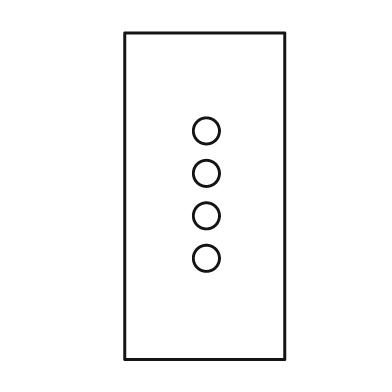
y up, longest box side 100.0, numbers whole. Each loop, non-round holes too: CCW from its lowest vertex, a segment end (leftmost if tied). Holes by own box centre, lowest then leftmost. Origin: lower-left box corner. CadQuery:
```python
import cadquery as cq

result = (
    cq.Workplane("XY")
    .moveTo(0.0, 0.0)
    .lineTo(49.0, 0.0)
    .lineTo(49.0, 100.0)
    .lineTo(0.0, 100.0)
    .close()
    .moveTo(25.0, 31.0)
    .circle(4.0)
    .moveTo(25.0, 44.0)
    .circle(4.0)
    .moveTo(25.0, 57.0)
    .circle(4.0)
    .moveTo(25.0, 70.0)
    .circle(4.0)
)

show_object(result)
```